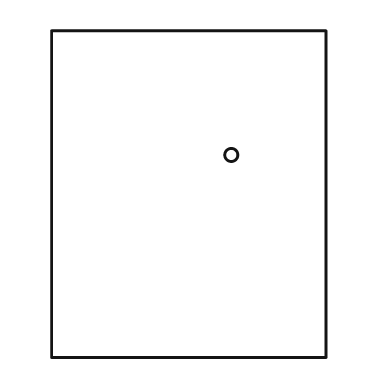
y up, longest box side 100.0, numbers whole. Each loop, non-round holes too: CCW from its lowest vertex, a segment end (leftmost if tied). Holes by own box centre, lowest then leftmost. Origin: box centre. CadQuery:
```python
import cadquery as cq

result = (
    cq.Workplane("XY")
    .moveTo(-42.0, -50.0)
    .lineTo(42.0, -50.0)
    .lineTo(42.0, 50.0)
    .lineTo(-42.0, 50.0)
    .close()
    .moveTo(13.0, 12.0)
    .circle(2.0)
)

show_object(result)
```